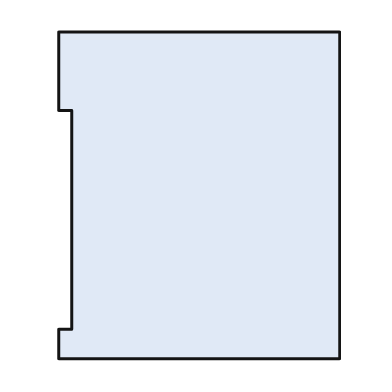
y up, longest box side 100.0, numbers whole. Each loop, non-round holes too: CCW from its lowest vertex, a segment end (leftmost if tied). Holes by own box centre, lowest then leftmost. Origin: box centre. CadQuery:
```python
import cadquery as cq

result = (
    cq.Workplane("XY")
    .moveTo(-43.0, -50.0)
    .lineTo(43.0, -50.0)
    .lineTo(43.0, 50.0)
    .lineTo(-43.0, 50.0)
    .lineTo(-43.0, 26.0)
    .lineTo(-39.0, 26.0)
    .lineTo(-39.0, -41.0)
    .lineTo(-43.0, -41.0)
    .close()
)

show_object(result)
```